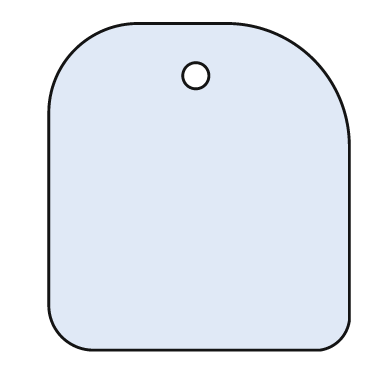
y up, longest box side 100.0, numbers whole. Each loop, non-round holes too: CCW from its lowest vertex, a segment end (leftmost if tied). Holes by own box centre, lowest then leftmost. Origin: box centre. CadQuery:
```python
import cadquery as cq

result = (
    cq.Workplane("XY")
    .moveTo(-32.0, -50.0)
    .lineTo(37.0, -50.0)
    .threePointArc((43.0, -47.0), (46.0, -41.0))
    .lineTo(46.0, 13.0)
    .threePointArc((35.0, 39.0), (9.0, 50.0))
    .lineTo(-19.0, 50.0)
    .threePointArc((-38.0, 42.0), (-46.0, 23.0))
    .lineTo(-46.0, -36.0)
    .threePointArc((-42.0, -46.0), (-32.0, -50.0))
    .close()
    .moveTo(-1.0, 34.0)
    .circle(4.0)
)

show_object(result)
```